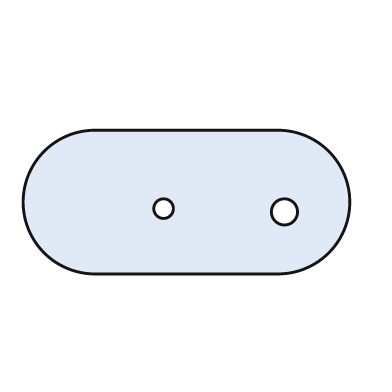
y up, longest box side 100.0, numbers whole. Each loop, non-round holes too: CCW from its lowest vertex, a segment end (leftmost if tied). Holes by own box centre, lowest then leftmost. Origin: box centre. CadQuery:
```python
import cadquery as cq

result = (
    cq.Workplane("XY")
    .moveTo(-28.0, -22.0)
    .lineTo(28.0, -22.0)
    .threePointArc((50.0, 0.0), (28.0, 22.0))
    .lineTo(-28.0, 22.0)
    .threePointArc((-50.0, 0.0), (-28.0, -22.0))
    .close()
    .moveTo(30.0, -3.0)
    .circle(4.0)
    .moveTo(-7.0, -2.0)
    .circle(3.0)
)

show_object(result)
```